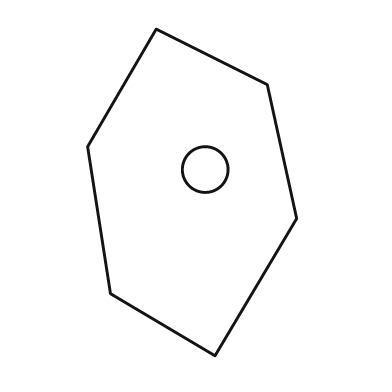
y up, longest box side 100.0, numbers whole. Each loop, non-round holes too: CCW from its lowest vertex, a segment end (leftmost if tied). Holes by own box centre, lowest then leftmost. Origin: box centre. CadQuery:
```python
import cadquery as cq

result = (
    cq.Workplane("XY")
    .moveTo(7.0, -50.0)
    .lineTo(32.0, -8.0)
    .lineTo(23.0, 33.0)
    .lineTo(-11.0, 50.0)
    .lineTo(-32.0, 14.0)
    .lineTo(-25.0, -31.0)
    .close()
    .moveTo(4.0, 7.0)
    .circle(7.0)
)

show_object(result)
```